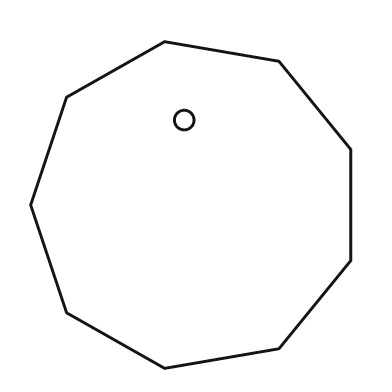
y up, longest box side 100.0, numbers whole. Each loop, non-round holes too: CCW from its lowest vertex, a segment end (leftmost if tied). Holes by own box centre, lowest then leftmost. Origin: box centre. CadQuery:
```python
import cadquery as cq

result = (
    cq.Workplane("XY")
    .moveTo(-8.0, -50.0)
    .lineTo(27.0, -44.0)
    .lineTo(49.0, -17.0)
    .lineTo(49.0, 17.0)
    .lineTo(27.0, 44.0)
    .lineTo(-8.0, 50.0)
    .lineTo(-38.0, 33.0)
    .lineTo(-49.0, 0.0)
    .lineTo(-38.0, -33.0)
    .close()
    .moveTo(-2.0, 26.0)
    .circle(3.0)
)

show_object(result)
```